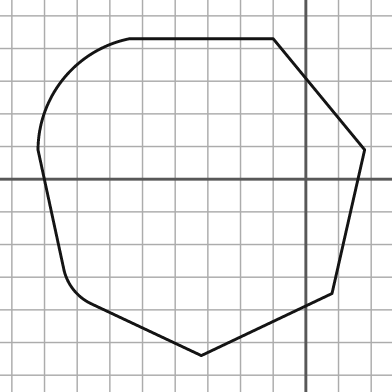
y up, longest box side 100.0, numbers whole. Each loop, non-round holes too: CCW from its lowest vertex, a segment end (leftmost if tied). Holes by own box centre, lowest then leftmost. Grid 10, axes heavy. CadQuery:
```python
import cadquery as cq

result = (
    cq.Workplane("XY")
    .moveTo(-32.0, -54.0)
    .lineTo(8.0, -35.0)
    .lineTo(18.0, 9.0)
    .lineTo(-10.0, 43.0)
    .lineTo(-54.0, 43.0)
    .threePointArc((-74.0, 31.0), (-82.0, 9.0))
    .lineTo(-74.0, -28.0)
    .threePointArc((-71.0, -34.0), (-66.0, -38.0))
    .close()
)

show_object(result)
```